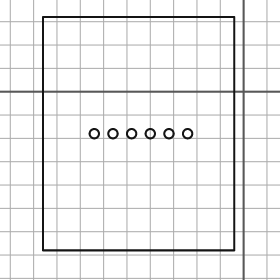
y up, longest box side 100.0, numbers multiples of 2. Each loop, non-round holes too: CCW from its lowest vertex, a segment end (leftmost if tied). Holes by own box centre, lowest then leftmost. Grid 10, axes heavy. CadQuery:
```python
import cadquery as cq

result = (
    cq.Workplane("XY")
    .moveTo(-86.0, -68.0)
    .lineTo(-4.0, -68.0)
    .lineTo(-4.0, 32.0)
    .lineTo(-86.0, 32.0)
    .close()
    .moveTo(-64.0, -18.0)
    .circle(2.0)
    .moveTo(-56.0, -18.0)
    .circle(2.0)
    .moveTo(-48.0, -18.0)
    .circle(2.0)
    .moveTo(-40.0, -18.0)
    .circle(2.0)
    .moveTo(-32.0, -18.0)
    .circle(2.0)
    .moveTo(-24.0, -18.0)
    .circle(2.0)
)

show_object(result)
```